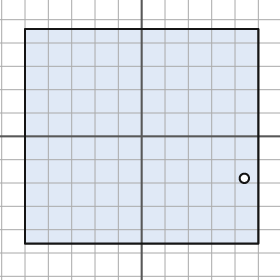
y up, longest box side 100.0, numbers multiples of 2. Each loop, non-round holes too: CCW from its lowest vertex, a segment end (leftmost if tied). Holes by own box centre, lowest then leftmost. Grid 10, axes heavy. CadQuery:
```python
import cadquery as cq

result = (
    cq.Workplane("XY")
    .moveTo(-50.0, -46.0)
    .lineTo(50.0, -46.0)
    .lineTo(50.0, 46.0)
    .lineTo(-50.0, 46.0)
    .close()
    .moveTo(44.0, -18.0)
    .circle(2.0)
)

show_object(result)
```